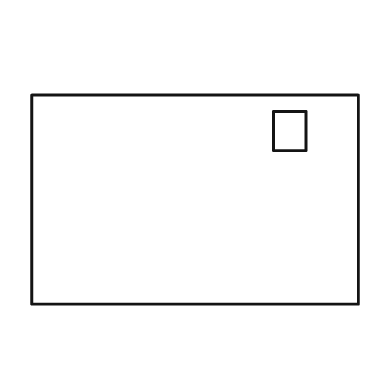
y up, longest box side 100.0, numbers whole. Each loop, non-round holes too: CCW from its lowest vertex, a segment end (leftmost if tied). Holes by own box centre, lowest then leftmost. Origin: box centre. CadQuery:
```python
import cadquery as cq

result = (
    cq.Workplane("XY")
    .moveTo(-50.0, -32.0)
    .lineTo(50.0, -32.0)
    .lineTo(50.0, 32.0)
    .lineTo(-50.0, 32.0)
    .close()
    .moveTo(24.0, 15.0)
    .lineTo(34.0, 15.0)
    .lineTo(34.0, 27.0)
    .lineTo(24.0, 27.0)
    .close()
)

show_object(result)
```